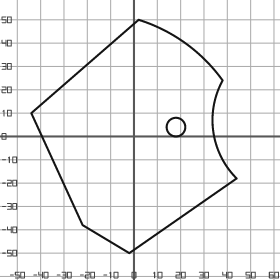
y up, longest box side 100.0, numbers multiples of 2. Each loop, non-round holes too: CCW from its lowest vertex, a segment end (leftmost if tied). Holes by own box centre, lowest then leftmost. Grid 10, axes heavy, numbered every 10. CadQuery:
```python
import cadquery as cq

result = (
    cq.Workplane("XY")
    .moveTo(-2.0, -50.0)
    .lineTo(44.0, -18.0)
    .threePointArc((34.0, 2.0), (38.0, 24.0))
    .threePointArc((22.0, 40.0), (2.0, 50.0))
    .lineTo(-44.0, 10.0)
    .lineTo(-22.0, -38.0)
    .close()
    .moveTo(18.0, 4.0)
    .circle(4.0)
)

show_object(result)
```